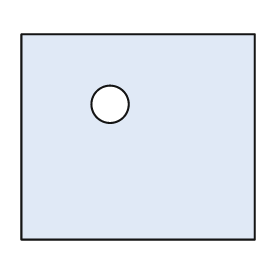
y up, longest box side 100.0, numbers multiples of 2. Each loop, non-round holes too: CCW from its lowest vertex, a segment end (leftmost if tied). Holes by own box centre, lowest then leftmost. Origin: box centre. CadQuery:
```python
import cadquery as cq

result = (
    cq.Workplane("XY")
    .moveTo(-50.0, -44.0)
    .lineTo(50.0, -44.0)
    .lineTo(50.0, 44.0)
    .lineTo(-50.0, 44.0)
    .close()
    .moveTo(-12.0, 14.0)
    .circle(8.0)
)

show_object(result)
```